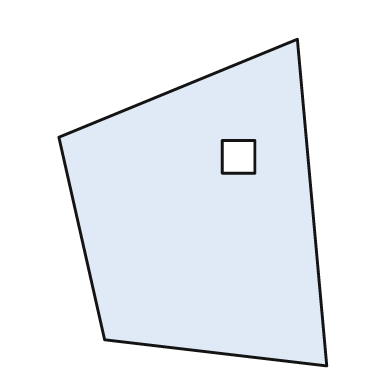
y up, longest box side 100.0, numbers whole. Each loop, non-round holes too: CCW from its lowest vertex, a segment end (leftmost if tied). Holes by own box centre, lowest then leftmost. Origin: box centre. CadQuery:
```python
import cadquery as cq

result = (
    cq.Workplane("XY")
    .moveTo(41.0, -50.0)
    .lineTo(32.0, 50.0)
    .lineTo(-41.0, 20.0)
    .lineTo(-27.0, -42.0)
    .close()
    .moveTo(9.0, 9.0)
    .lineTo(19.0, 9.0)
    .lineTo(19.0, 19.0)
    .lineTo(9.0, 19.0)
    .close()
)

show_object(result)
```